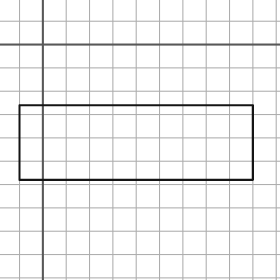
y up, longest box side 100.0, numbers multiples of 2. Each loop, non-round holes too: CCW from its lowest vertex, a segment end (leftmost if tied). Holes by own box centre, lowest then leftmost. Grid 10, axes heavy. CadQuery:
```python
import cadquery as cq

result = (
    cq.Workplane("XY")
    .moveTo(-10.0, -58.0)
    .lineTo(90.0, -58.0)
    .lineTo(90.0, -26.0)
    .lineTo(-10.0, -26.0)
    .close()
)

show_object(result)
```